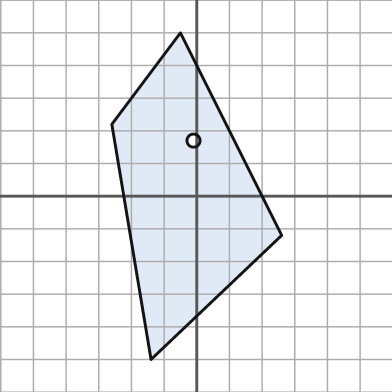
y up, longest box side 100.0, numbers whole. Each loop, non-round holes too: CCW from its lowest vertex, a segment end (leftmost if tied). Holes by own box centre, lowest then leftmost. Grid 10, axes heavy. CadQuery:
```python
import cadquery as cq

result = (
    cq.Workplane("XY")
    .moveTo(-14.0, -50.0)
    .lineTo(26.0, -12.0)
    .lineTo(-5.0, 50.0)
    .lineTo(-26.0, 22.0)
    .close()
    .moveTo(-1.0, 17.0)
    .circle(2.0)
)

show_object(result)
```